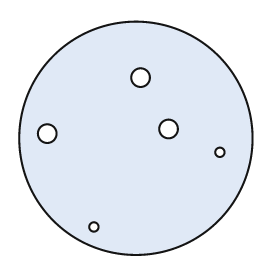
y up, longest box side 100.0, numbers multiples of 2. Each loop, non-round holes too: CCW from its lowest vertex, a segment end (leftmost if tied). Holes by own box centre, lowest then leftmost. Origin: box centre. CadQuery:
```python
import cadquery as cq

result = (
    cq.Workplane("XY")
    .moveTo(0.0, 0.0)
    .circle(50.0)
    .moveTo(-18.0, -38.0)
    .circle(2.0)
    .moveTo(36.0, -6.0)
    .circle(2.0)
    .moveTo(-38.0, 2.0)
    .circle(4.0)
    .moveTo(14.0, 4.0)
    .circle(4.0)
    .moveTo(2.0, 26.0)
    .circle(4.0)
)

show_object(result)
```